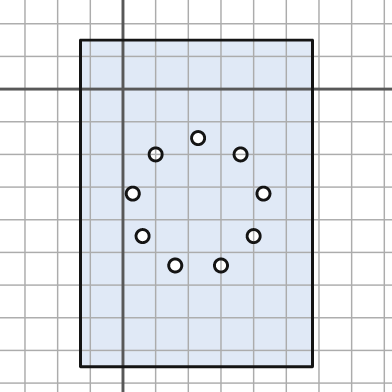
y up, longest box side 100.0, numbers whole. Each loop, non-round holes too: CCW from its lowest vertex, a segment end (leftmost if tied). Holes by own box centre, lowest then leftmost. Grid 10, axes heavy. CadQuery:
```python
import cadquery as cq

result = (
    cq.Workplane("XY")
    .moveTo(-13.0, -85.0)
    .lineTo(58.0, -85.0)
    .lineTo(58.0, 15.0)
    .lineTo(-13.0, 15.0)
    .close()
    .moveTo(16.0, -54.0)
    .circle(2.0)
    .moveTo(30.0, -54.0)
    .circle(2.0)
    .moveTo(6.0, -45.0)
    .circle(2.0)
    .moveTo(40.0, -45.0)
    .circle(2.0)
    .moveTo(3.0, -32.0)
    .circle(2.0)
    .moveTo(43.0, -32.0)
    .circle(2.0)
    .moveTo(10.0, -20.0)
    .circle(2.0)
    .moveTo(36.0, -20.0)
    .circle(2.0)
    .moveTo(23.0, -15.0)
    .circle(2.0)
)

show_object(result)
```